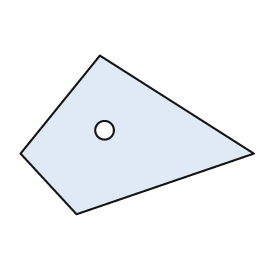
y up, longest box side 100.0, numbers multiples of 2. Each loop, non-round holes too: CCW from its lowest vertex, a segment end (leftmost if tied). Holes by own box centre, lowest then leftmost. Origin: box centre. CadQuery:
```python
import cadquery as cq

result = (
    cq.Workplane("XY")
    .moveTo(-26.0, -34.0)
    .lineTo(50.0, -8.0)
    .lineTo(-16.0, 34.0)
    .lineTo(-50.0, -8.0)
    .close()
    .moveTo(-14.0, 2.0)
    .circle(4.0)
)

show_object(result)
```